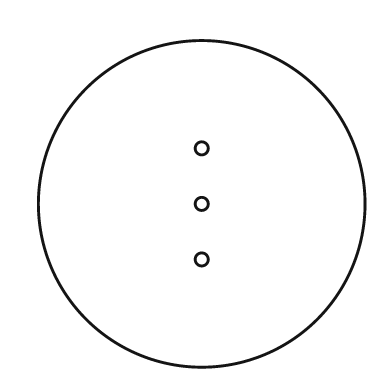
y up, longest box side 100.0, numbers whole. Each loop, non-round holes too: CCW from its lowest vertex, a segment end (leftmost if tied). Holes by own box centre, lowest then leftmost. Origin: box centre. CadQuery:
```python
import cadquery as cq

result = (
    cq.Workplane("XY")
    .moveTo(0.0, 0.0)
    .circle(50.0)
    .moveTo(0.0, -17.0)
    .circle(2.0)
    .moveTo(0.0, 0.0)
    .circle(2.0)
    .moveTo(0.0, 17.0)
    .circle(2.0)
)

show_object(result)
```